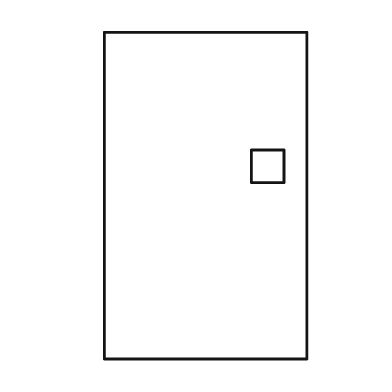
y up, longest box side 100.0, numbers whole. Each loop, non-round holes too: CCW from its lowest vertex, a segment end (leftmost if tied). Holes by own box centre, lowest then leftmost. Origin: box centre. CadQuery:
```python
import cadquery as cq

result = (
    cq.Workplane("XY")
    .moveTo(-31.0, -50.0)
    .lineTo(31.0, -50.0)
    .lineTo(31.0, 50.0)
    .lineTo(-31.0, 50.0)
    .close()
    .moveTo(14.0, 4.0)
    .lineTo(24.0, 4.0)
    .lineTo(24.0, 14.0)
    .lineTo(14.0, 14.0)
    .close()
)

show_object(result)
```